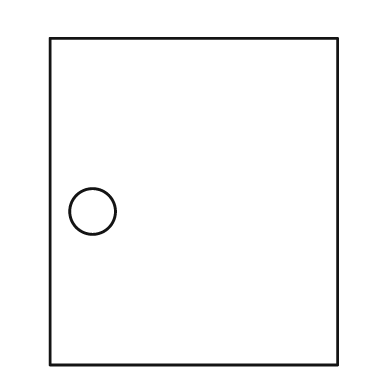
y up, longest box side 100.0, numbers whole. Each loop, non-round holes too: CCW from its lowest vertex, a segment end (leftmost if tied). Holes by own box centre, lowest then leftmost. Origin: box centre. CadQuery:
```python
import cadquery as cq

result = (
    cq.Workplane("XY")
    .moveTo(-44.0, -50.0)
    .lineTo(44.0, -50.0)
    .lineTo(44.0, 50.0)
    .lineTo(-44.0, 50.0)
    .close()
    .moveTo(-31.0, -3.0)
    .circle(7.0)
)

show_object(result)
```